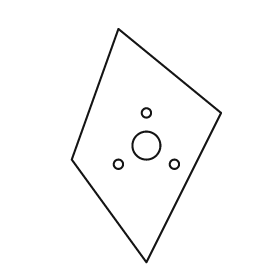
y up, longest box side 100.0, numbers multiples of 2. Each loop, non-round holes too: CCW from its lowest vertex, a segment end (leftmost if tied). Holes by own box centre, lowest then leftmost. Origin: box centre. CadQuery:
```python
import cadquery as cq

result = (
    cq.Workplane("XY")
    .moveTo(0.0, -50.0)
    .lineTo(32.0, 14.0)
    .lineTo(-12.0, 50.0)
    .lineTo(-32.0, -6.0)
    .close()
    .moveTo(-12.0, -8.0)
    .circle(2.0)
    .moveTo(12.0, -8.0)
    .circle(2.0)
    .moveTo(0.0, 0.0)
    .circle(6.0)
    .moveTo(0.0, 14.0)
    .circle(2.0)
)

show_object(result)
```